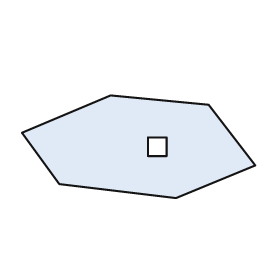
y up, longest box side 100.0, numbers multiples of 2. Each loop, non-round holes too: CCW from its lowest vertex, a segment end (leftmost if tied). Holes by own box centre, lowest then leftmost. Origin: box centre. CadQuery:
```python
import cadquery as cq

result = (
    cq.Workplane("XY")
    .moveTo(16.0, -22.0)
    .lineTo(50.0, -8.0)
    .lineTo(30.0, 18.0)
    .lineTo(-12.0, 22.0)
    .lineTo(-50.0, 6.0)
    .lineTo(-34.0, -16.0)
    .close()
    .moveTo(4.0, -4.0)
    .lineTo(12.0, -4.0)
    .lineTo(12.0, 4.0)
    .lineTo(4.0, 4.0)
    .close()
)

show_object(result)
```